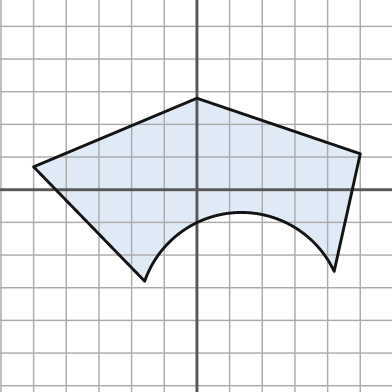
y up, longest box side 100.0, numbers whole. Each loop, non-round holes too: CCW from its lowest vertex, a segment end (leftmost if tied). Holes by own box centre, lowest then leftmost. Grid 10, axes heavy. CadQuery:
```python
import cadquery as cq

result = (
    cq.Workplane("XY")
    .moveTo(-16.0, -28.0)
    .threePointArc((12.0, -7.0), (42.0, -25.0))
    .lineTo(50.0, 11.0)
    .lineTo(0.0, 28.0)
    .lineTo(-50.0, 7.0)
    .close()
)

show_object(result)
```